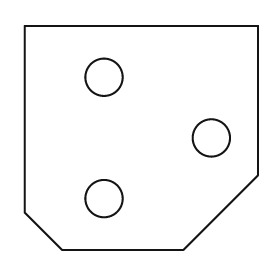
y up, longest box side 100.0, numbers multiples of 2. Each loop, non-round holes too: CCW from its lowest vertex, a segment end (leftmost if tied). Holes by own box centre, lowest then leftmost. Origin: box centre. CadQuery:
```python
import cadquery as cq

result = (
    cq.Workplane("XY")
    .moveTo(-34.0, -48.0)
    .lineTo(18.0, -48.0)
    .lineTo(50.0, -16.0)
    .lineTo(50.0, 48.0)
    .lineTo(-50.0, 48.0)
    .lineTo(-50.0, -32.0)
    .close()
    .moveTo(-16.0, -26.0)
    .circle(8.0)
    .moveTo(30.0, 0.0)
    .circle(8.0)
    .moveTo(-16.0, 26.0)
    .circle(8.0)
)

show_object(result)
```